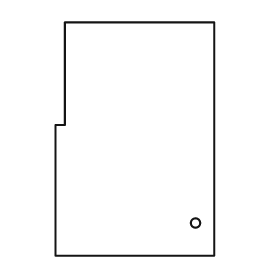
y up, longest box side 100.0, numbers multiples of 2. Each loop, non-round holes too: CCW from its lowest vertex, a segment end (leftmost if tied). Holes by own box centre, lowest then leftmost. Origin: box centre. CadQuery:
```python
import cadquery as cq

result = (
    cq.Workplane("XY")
    .moveTo(-34.0, -50.0)
    .lineTo(34.0, -50.0)
    .lineTo(34.0, 50.0)
    .lineTo(-30.0, 50.0)
    .lineTo(-30.0, 6.0)
    .lineTo(-34.0, 6.0)
    .close()
    .moveTo(26.0, -36.0)
    .circle(2.0)
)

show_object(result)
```